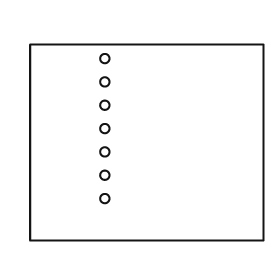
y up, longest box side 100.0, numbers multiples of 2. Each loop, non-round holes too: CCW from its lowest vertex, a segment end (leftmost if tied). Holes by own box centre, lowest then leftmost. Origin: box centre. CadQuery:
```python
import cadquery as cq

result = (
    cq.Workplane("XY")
    .moveTo(-50.0, -42.0)
    .lineTo(50.0, -42.0)
    .lineTo(50.0, 42.0)
    .lineTo(-50.0, 42.0)
    .close()
    .moveTo(-18.0, -24.0)
    .circle(2.0)
    .moveTo(-18.0, -14.0)
    .circle(2.0)
    .moveTo(-18.0, -4.0)
    .circle(2.0)
    .moveTo(-18.0, 6.0)
    .circle(2.0)
    .moveTo(-18.0, 16.0)
    .circle(2.0)
    .moveTo(-18.0, 26.0)
    .circle(2.0)
    .moveTo(-18.0, 36.0)
    .circle(2.0)
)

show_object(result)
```